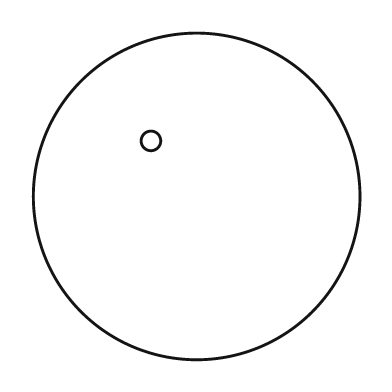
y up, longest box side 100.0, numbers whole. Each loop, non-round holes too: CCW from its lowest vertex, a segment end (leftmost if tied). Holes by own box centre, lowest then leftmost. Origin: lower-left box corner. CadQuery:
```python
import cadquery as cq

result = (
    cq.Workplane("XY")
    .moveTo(50.0, 50.0)
    .circle(50.0)
    .moveTo(36.0, 67.0)
    .circle(3.0)
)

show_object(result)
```